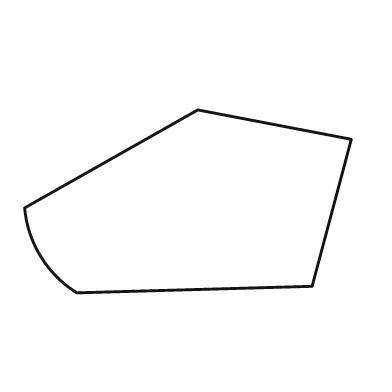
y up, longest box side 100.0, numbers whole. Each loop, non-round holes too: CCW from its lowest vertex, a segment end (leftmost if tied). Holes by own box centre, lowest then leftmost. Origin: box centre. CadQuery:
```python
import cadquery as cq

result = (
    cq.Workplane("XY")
    .moveTo(-34.0, -28.0)
    .lineTo(38.0, -26.0)
    .lineTo(50.0, 19.0)
    .lineTo(3.0, 28.0)
    .lineTo(-50.0, -2.0)
    .threePointArc((-45.0, -17.0), (-34.0, -28.0))
    .close()
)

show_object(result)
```